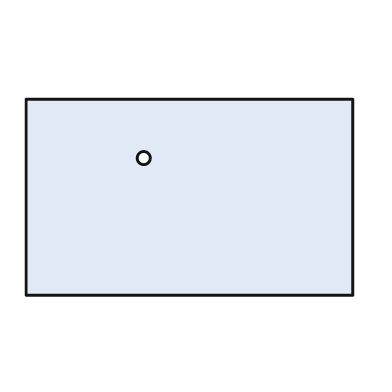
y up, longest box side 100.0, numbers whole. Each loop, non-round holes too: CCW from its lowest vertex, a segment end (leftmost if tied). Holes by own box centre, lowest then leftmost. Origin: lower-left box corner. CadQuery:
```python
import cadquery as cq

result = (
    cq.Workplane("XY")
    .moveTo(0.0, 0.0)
    .lineTo(100.0, 0.0)
    .lineTo(100.0, 60.0)
    .lineTo(0.0, 60.0)
    .close()
    .moveTo(36.0, 42.0)
    .circle(2.0)
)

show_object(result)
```